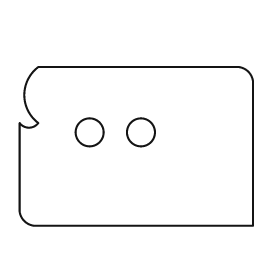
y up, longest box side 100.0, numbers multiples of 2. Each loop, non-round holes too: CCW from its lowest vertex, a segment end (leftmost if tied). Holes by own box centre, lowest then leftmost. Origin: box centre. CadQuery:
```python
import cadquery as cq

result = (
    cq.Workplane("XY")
    .moveTo(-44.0, -34.0)
    .lineTo(50.0, -34.0)
    .lineTo(50.0, 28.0)
    .threePointArc((48.0, 32.0), (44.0, 34.0))
    .lineTo(-42.0, 34.0)
    .threePointArc((-48.0, 22.0), (-42.0, 10.0))
    .threePointArc((-46.0, 8.0), (-50.0, 10.0))
    .lineTo(-50.0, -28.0)
    .threePointArc((-48.0, -32.0), (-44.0, -34.0))
    .close()
    .moveTo(-20.0, 6.0)
    .circle(6.0)
    .moveTo(2.0, 6.0)
    .circle(6.0)
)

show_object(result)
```